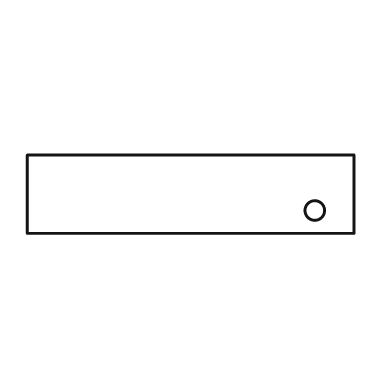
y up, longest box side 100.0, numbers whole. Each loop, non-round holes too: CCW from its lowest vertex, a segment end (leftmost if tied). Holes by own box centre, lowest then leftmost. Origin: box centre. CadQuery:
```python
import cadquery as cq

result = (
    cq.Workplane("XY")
    .moveTo(-50.0, -12.0)
    .lineTo(50.0, -12.0)
    .lineTo(50.0, 12.0)
    .lineTo(-50.0, 12.0)
    .close()
    .moveTo(38.0, -5.0)
    .circle(3.0)
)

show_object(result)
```